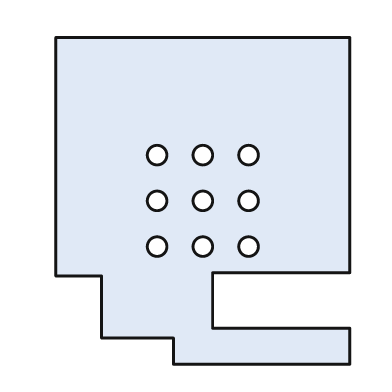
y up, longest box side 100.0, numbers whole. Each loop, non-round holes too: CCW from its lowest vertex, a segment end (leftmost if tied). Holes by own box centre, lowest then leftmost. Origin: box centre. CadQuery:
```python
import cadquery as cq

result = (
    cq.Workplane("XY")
    .moveTo(-9.0, -50.0)
    .lineTo(45.0, -50.0)
    .lineTo(45.0, -39.0)
    .lineTo(3.0, -39.0)
    .lineTo(3.0, -22.0)
    .lineTo(45.0, -22.0)
    .lineTo(45.0, 50.0)
    .lineTo(-45.0, 50.0)
    .lineTo(-45.0, -23.0)
    .lineTo(-31.0, -23.0)
    .lineTo(-31.0, -42.0)
    .lineTo(-9.0, -42.0)
    .close()
    .moveTo(-14.0, -14.0)
    .circle(3.0)
    .moveTo(0.0, -14.0)
    .circle(3.0)
    .moveTo(14.0, -14.0)
    .circle(3.0)
    .moveTo(-14.0, 0.0)
    .circle(3.0)
    .moveTo(0.0, 0.0)
    .circle(3.0)
    .moveTo(14.0, 0.0)
    .circle(3.0)
    .moveTo(-14.0, 14.0)
    .circle(3.0)
    .moveTo(0.0, 14.0)
    .circle(3.0)
    .moveTo(14.0, 14.0)
    .circle(3.0)
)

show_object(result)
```